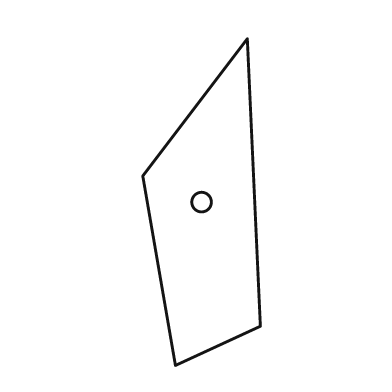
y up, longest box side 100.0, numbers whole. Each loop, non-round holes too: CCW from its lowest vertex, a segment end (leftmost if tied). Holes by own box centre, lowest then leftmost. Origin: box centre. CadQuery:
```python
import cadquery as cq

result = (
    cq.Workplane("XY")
    .moveTo(-8.0, -50.0)
    .lineTo(18.0, -38.0)
    .lineTo(14.0, 50.0)
    .lineTo(-18.0, 8.0)
    .close()
    .moveTo(0.0, 0.0)
    .circle(3.0)
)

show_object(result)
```